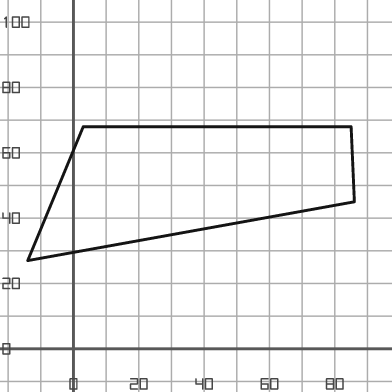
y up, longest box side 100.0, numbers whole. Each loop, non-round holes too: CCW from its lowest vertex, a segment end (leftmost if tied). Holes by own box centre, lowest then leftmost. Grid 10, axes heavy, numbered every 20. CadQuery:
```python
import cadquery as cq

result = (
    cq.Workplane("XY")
    .moveTo(-14.0, 27.0)
    .lineTo(86.0, 45.0)
    .lineTo(85.0, 68.0)
    .lineTo(3.0, 68.0)
    .close()
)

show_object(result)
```